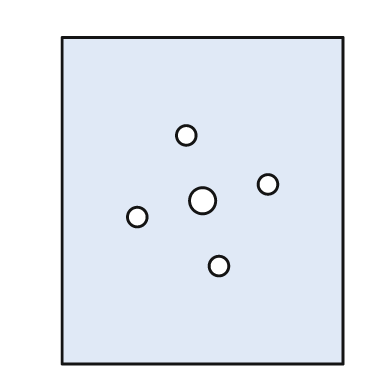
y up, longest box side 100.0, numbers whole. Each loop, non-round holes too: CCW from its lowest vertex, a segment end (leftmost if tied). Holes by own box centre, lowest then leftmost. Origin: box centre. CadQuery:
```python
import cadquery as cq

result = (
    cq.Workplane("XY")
    .moveTo(-43.0, -50.0)
    .lineTo(43.0, -50.0)
    .lineTo(43.0, 50.0)
    .lineTo(-43.0, 50.0)
    .close()
    .moveTo(5.0, -20.0)
    .circle(3.0)
    .moveTo(-20.0, -5.0)
    .circle(3.0)
    .moveTo(0.0, 0.0)
    .circle(4.0)
    .moveTo(20.0, 5.0)
    .circle(3.0)
    .moveTo(-5.0, 20.0)
    .circle(3.0)
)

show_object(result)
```